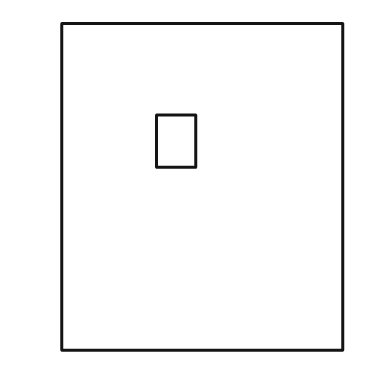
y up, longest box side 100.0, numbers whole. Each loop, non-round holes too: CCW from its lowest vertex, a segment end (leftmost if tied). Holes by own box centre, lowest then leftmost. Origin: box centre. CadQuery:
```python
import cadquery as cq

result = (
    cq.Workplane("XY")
    .moveTo(-43.0, -50.0)
    .lineTo(43.0, -50.0)
    .lineTo(43.0, 50.0)
    .lineTo(-43.0, 50.0)
    .close()
    .moveTo(-14.0, 6.0)
    .lineTo(-2.0, 6.0)
    .lineTo(-2.0, 22.0)
    .lineTo(-14.0, 22.0)
    .close()
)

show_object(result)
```